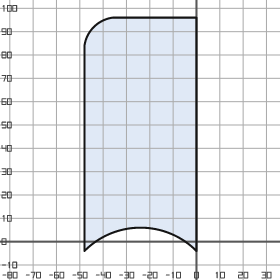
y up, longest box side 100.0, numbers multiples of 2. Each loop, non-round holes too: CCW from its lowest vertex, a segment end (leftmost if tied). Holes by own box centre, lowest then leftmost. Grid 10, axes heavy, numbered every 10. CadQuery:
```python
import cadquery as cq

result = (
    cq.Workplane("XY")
    .moveTo(-48.0, -4.0)
    .threePointArc((-24.0, 6.0), (0.0, -4.0))
    .lineTo(0.0, 96.0)
    .lineTo(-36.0, 96.0)
    .threePointArc((-44.0, 92.0), (-48.0, 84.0))
    .close()
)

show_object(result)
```